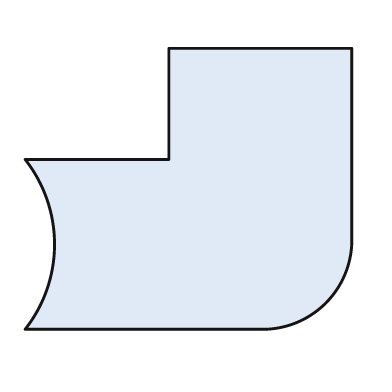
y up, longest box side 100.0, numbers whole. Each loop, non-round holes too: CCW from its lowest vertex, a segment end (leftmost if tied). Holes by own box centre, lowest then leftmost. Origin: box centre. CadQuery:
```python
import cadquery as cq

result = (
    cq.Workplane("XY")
    .moveTo(-50.0, -43.0)
    .lineTo(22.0, -43.0)
    .threePointArc((42.0, -35.0), (50.0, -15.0))
    .lineTo(50.0, 43.0)
    .lineTo(-6.0, 43.0)
    .lineTo(-6.0, 9.0)
    .lineTo(-50.0, 9.0)
    .threePointArc((-41.0, -17.0), (-50.0, -43.0))
    .close()
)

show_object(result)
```